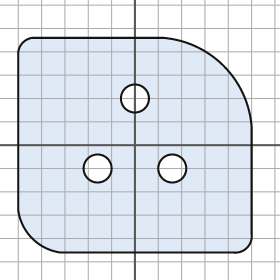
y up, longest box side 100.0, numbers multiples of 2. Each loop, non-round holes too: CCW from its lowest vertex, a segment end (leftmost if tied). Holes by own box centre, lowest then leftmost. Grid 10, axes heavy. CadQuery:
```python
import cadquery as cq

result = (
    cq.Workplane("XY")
    .moveTo(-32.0, -46.0)
    .lineTo(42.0, -46.0)
    .threePointArc((48.0, -44.0), (50.0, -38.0))
    .lineTo(50.0, 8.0)
    .threePointArc((38.0, 34.0), (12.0, 46.0))
    .lineTo(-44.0, 46.0)
    .threePointArc((-48.0, 44.0), (-50.0, 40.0))
    .lineTo(-50.0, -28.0)
    .threePointArc((-44.0, -40.0), (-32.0, -46.0))
    .close()
    .moveTo(-16.0, -10.0)
    .circle(6.0)
    .moveTo(16.0, -10.0)
    .circle(6.0)
    .moveTo(0.0, 20.0)
    .circle(6.0)
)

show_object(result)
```